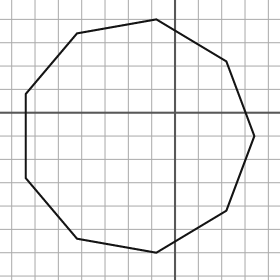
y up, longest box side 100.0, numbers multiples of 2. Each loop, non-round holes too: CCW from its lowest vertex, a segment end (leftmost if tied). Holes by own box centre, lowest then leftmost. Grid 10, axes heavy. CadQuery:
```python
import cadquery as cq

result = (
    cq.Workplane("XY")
    .moveTo(-8.0, -60.0)
    .lineTo(22.0, -42.0)
    .lineTo(34.0, -10.0)
    .lineTo(22.0, 22.0)
    .lineTo(-8.0, 40.0)
    .lineTo(-42.0, 34.0)
    .lineTo(-64.0, 8.0)
    .lineTo(-64.0, -28.0)
    .lineTo(-42.0, -54.0)
    .close()
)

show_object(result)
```